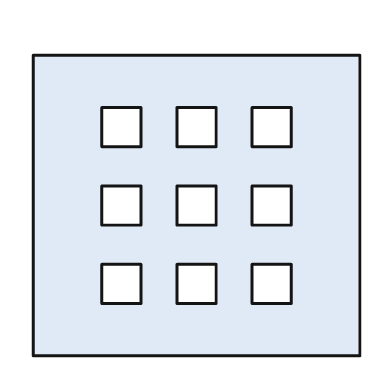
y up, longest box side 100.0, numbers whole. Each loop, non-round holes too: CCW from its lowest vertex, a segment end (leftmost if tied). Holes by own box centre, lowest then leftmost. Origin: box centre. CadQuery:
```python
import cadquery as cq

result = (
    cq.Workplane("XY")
    .moveTo(-50.0, -46.0)
    .lineTo(50.0, -46.0)
    .lineTo(50.0, 46.0)
    .lineTo(-50.0, 46.0)
    .close()
    .moveTo(-29.0, -30.0)
    .lineTo(-17.0, -30.0)
    .lineTo(-17.0, -18.0)
    .lineTo(-29.0, -18.0)
    .close()
    .moveTo(-6.0, -30.0)
    .lineTo(6.0, -30.0)
    .lineTo(6.0, -18.0)
    .lineTo(-6.0, -18.0)
    .close()
    .moveTo(17.0, -30.0)
    .lineTo(29.0, -30.0)
    .lineTo(29.0, -18.0)
    .lineTo(17.0, -18.0)
    .close()
    .moveTo(-29.0, -6.0)
    .lineTo(-17.0, -6.0)
    .lineTo(-17.0, 6.0)
    .lineTo(-29.0, 6.0)
    .close()
    .moveTo(-6.0, -6.0)
    .lineTo(6.0, -6.0)
    .lineTo(6.0, 6.0)
    .lineTo(-6.0, 6.0)
    .close()
    .moveTo(17.0, -6.0)
    .lineTo(29.0, -6.0)
    .lineTo(29.0, 6.0)
    .lineTo(17.0, 6.0)
    .close()
    .moveTo(-29.0, 18.0)
    .lineTo(-17.0, 18.0)
    .lineTo(-17.0, 30.0)
    .lineTo(-29.0, 30.0)
    .close()
    .moveTo(-6.0, 18.0)
    .lineTo(6.0, 18.0)
    .lineTo(6.0, 30.0)
    .lineTo(-6.0, 30.0)
    .close()
    .moveTo(17.0, 18.0)
    .lineTo(29.0, 18.0)
    .lineTo(29.0, 30.0)
    .lineTo(17.0, 30.0)
    .close()
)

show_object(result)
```